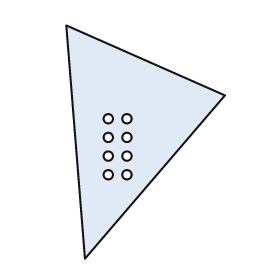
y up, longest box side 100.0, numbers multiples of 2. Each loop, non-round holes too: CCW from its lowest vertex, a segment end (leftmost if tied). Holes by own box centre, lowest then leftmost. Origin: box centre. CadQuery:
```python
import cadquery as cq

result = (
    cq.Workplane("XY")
    .moveTo(-26.0, -50.0)
    .lineTo(34.0, 20.0)
    .lineTo(-34.0, 50.0)
    .close()
    .moveTo(-16.0, -14.0)
    .circle(2.0)
    .moveTo(-8.0, -14.0)
    .circle(2.0)
    .moveTo(-16.0, -6.0)
    .circle(2.0)
    .moveTo(-8.0, -6.0)
    .circle(2.0)
    .moveTo(-16.0, 2.0)
    .circle(2.0)
    .moveTo(-8.0, 2.0)
    .circle(2.0)
    .moveTo(-16.0, 10.0)
    .circle(2.0)
    .moveTo(-8.0, 10.0)
    .circle(2.0)
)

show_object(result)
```